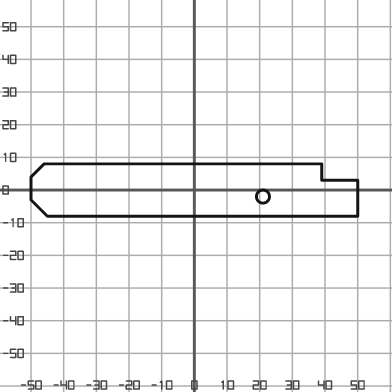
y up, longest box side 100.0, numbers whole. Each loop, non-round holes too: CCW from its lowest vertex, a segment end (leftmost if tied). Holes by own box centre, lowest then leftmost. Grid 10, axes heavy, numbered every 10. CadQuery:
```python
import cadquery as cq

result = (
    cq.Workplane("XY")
    .moveTo(-45.0, -8.0)
    .lineTo(50.0, -8.0)
    .lineTo(50.0, 3.0)
    .lineTo(39.0, 3.0)
    .lineTo(39.0, 8.0)
    .lineTo(-46.0, 8.0)
    .lineTo(-50.0, 4.0)
    .lineTo(-50.0, -3.0)
    .close()
    .moveTo(21.0, -2.0)
    .circle(2.0)
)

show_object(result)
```